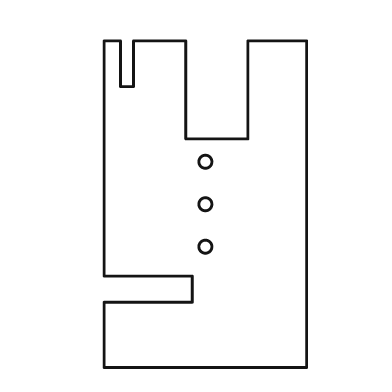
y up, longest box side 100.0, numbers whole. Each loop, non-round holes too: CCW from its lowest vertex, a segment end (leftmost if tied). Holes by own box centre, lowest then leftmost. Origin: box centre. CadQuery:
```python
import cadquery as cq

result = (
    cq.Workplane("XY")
    .moveTo(-31.0, -50.0)
    .lineTo(31.0, -50.0)
    .lineTo(31.0, 50.0)
    .lineTo(13.0, 50.0)
    .lineTo(13.0, 20.0)
    .lineTo(-6.0, 20.0)
    .lineTo(-6.0, 50.0)
    .lineTo(-22.0, 50.0)
    .lineTo(-22.0, 36.0)
    .lineTo(-26.0, 36.0)
    .lineTo(-26.0, 50.0)
    .lineTo(-31.0, 50.0)
    .lineTo(-31.0, -22.0)
    .lineTo(-4.0, -22.0)
    .lineTo(-4.0, -30.0)
    .lineTo(-31.0, -30.0)
    .close()
    .moveTo(0.0, -13.0)
    .circle(2.0)
    .moveTo(0.0, 0.0)
    .circle(2.0)
    .moveTo(0.0, 13.0)
    .circle(2.0)
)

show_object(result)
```